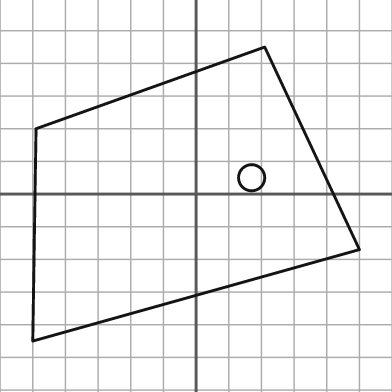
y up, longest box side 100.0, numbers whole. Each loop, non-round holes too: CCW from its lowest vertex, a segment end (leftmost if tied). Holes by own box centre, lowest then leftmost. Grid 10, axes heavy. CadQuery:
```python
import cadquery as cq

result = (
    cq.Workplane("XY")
    .moveTo(-50.0, -45.0)
    .lineTo(50.0, -17.0)
    .lineTo(21.0, 45.0)
    .lineTo(-49.0, 20.0)
    .close()
    .moveTo(17.0, 5.0)
    .circle(4.0)
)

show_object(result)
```